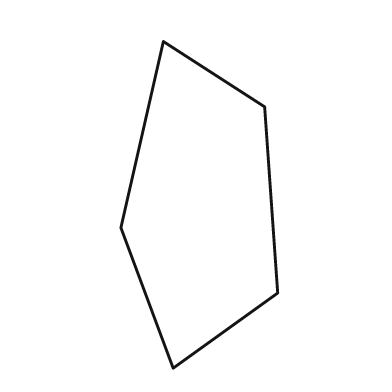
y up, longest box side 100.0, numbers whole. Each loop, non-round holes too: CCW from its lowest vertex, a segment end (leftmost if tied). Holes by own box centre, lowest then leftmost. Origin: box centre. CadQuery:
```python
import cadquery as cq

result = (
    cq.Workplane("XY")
    .moveTo(-8.0, -50.0)
    .lineTo(24.0, -27.0)
    .lineTo(20.0, 30.0)
    .lineTo(-11.0, 50.0)
    .lineTo(-24.0, -7.0)
    .close()
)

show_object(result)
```